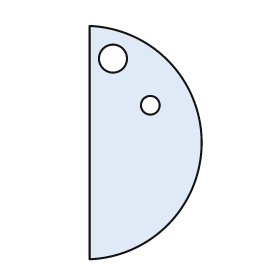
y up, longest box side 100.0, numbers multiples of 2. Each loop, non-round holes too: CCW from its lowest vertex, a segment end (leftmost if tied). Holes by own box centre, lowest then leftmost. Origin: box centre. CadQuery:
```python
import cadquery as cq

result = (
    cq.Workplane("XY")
    .moveTo(-24.0, -50.0)
    .threePointArc((24.0, 0.0), (-24.0, 50.0))
    .close()
    .moveTo(2.0, 16.0)
    .circle(4.0)
    .moveTo(-14.0, 36.0)
    .circle(6.0)
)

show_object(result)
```